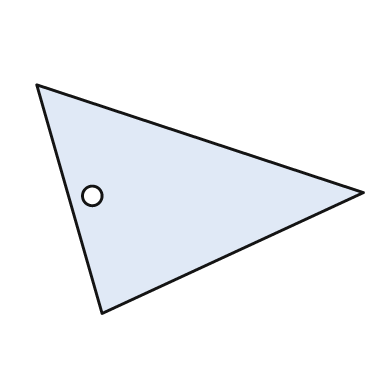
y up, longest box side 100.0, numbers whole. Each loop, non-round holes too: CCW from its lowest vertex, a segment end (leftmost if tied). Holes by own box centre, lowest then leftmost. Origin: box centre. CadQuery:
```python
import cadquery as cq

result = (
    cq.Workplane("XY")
    .moveTo(-30.0, -35.0)
    .lineTo(50.0, 2.0)
    .lineTo(-50.0, 35.0)
    .close()
    .moveTo(-33.0, 1.0)
    .circle(3.0)
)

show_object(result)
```